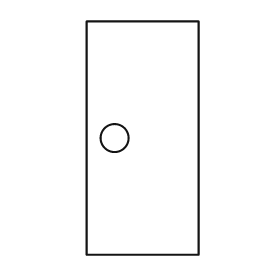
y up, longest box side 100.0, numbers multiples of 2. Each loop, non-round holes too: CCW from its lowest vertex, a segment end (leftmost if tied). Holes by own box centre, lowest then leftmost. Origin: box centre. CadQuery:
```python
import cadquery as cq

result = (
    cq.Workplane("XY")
    .moveTo(-24.0, -50.0)
    .lineTo(24.0, -50.0)
    .lineTo(24.0, 50.0)
    .lineTo(-24.0, 50.0)
    .close()
    .moveTo(-12.0, 0.0)
    .circle(6.0)
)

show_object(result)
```